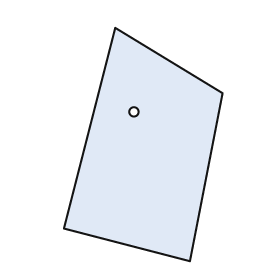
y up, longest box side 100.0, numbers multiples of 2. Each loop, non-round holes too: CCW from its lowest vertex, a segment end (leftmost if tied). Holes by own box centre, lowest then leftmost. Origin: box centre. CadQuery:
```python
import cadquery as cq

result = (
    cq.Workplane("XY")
    .moveTo(20.0, -50.0)
    .lineTo(34.0, 22.0)
    .lineTo(-12.0, 50.0)
    .lineTo(-34.0, -36.0)
    .close()
    .moveTo(-4.0, 14.0)
    .circle(2.0)
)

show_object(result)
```